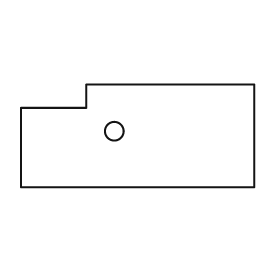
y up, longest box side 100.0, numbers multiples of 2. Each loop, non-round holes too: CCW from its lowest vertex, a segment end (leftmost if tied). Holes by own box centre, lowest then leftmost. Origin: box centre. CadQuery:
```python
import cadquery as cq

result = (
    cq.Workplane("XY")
    .moveTo(-50.0, -22.0)
    .lineTo(50.0, -22.0)
    .lineTo(50.0, 22.0)
    .lineTo(-22.0, 22.0)
    .lineTo(-22.0, 12.0)
    .lineTo(-50.0, 12.0)
    .close()
    .moveTo(-10.0, 2.0)
    .circle(4.0)
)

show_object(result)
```